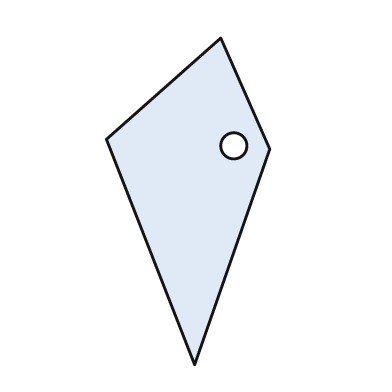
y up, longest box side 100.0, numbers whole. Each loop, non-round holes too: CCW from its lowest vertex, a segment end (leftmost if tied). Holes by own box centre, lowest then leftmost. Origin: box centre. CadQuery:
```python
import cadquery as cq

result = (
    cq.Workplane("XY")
    .moveTo(2.0, -50.0)
    .lineTo(25.0, 16.0)
    .lineTo(10.0, 50.0)
    .lineTo(-25.0, 19.0)
    .close()
    .moveTo(14.0, 17.0)
    .circle(4.0)
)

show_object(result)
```